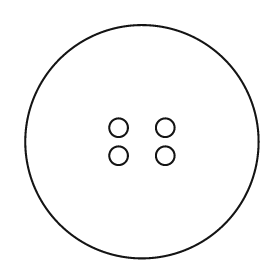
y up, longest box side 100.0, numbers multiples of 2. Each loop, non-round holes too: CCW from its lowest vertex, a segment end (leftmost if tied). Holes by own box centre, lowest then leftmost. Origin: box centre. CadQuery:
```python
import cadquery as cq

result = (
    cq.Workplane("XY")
    .moveTo(0.0, 0.0)
    .circle(50.0)
    .moveTo(-10.0, -6.0)
    .circle(4.0)
    .moveTo(10.0, -6.0)
    .circle(4.0)
    .moveTo(-10.0, 6.0)
    .circle(4.0)
    .moveTo(10.0, 6.0)
    .circle(4.0)
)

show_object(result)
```